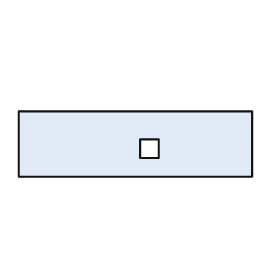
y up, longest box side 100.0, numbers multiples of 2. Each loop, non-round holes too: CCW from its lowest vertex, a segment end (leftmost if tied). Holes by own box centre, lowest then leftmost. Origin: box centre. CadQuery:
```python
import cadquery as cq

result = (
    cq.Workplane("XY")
    .moveTo(-50.0, -14.0)
    .lineTo(50.0, -14.0)
    .lineTo(50.0, 14.0)
    .lineTo(-50.0, 14.0)
    .close()
    .moveTo(2.0, -6.0)
    .lineTo(10.0, -6.0)
    .lineTo(10.0, 2.0)
    .lineTo(2.0, 2.0)
    .close()
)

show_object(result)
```